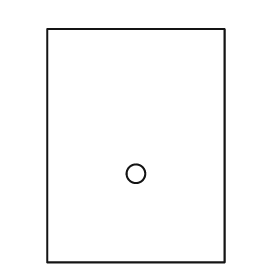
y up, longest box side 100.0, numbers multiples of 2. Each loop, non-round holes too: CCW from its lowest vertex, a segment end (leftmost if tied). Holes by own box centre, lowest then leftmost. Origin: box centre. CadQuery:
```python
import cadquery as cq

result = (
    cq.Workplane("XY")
    .moveTo(-38.0, -50.0)
    .lineTo(38.0, -50.0)
    .lineTo(38.0, 50.0)
    .lineTo(-38.0, 50.0)
    .close()
    .moveTo(0.0, -12.0)
    .circle(4.0)
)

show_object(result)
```